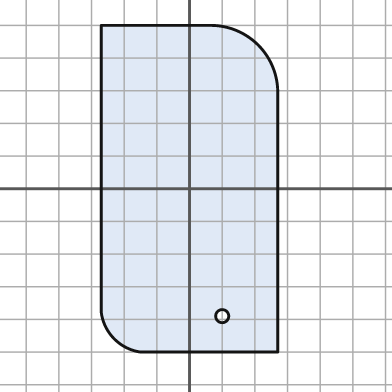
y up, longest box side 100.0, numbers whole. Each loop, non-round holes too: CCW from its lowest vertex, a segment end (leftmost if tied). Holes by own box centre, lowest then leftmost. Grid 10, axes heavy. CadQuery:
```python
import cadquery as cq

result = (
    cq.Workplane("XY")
    .moveTo(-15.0, -50.0)
    .lineTo(27.0, -50.0)
    .lineTo(27.0, 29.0)
    .threePointArc((21.0, 44.0), (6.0, 50.0))
    .lineTo(-27.0, 50.0)
    .lineTo(-27.0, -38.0)
    .threePointArc((-23.0, -46.0), (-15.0, -50.0))
    .close()
    .moveTo(10.0, -39.0)
    .circle(2.0)
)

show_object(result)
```